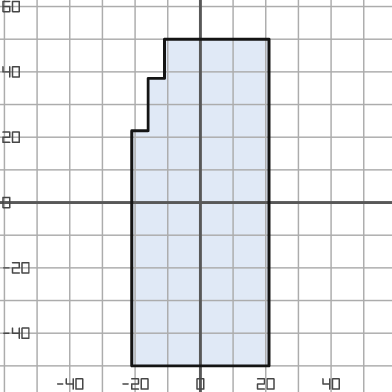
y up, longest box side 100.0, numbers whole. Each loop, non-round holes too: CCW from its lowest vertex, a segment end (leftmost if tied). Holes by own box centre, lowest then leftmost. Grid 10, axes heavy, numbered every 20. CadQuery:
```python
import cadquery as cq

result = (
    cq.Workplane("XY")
    .moveTo(-21.0, -50.0)
    .lineTo(21.0, -50.0)
    .lineTo(21.0, 50.0)
    .lineTo(-11.0, 50.0)
    .lineTo(-11.0, 38.0)
    .lineTo(-16.0, 38.0)
    .lineTo(-16.0, 22.0)
    .lineTo(-21.0, 22.0)
    .close()
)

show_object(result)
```